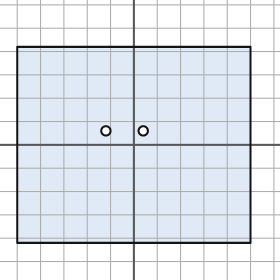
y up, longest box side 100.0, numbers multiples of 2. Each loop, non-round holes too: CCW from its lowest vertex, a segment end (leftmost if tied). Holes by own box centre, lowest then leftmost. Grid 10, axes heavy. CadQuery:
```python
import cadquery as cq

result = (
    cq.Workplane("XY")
    .moveTo(-50.0, -42.0)
    .lineTo(50.0, -42.0)
    .lineTo(50.0, 42.0)
    .lineTo(-50.0, 42.0)
    .close()
    .moveTo(-12.0, 6.0)
    .circle(2.0)
    .moveTo(4.0, 6.0)
    .circle(2.0)
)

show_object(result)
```